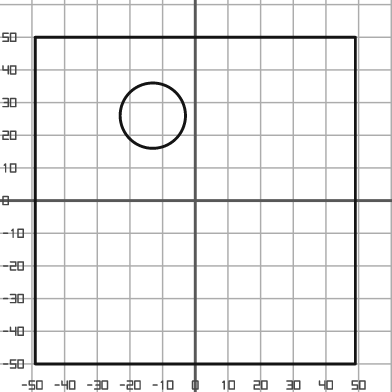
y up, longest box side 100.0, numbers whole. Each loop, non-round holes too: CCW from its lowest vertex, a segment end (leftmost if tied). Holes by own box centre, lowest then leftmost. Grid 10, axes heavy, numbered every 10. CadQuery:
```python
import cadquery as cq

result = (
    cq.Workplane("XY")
    .moveTo(-49.0, -50.0)
    .lineTo(49.0, -50.0)
    .lineTo(49.0, 50.0)
    .lineTo(-49.0, 50.0)
    .close()
    .moveTo(-13.0, 26.0)
    .circle(10.0)
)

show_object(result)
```